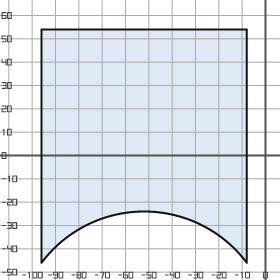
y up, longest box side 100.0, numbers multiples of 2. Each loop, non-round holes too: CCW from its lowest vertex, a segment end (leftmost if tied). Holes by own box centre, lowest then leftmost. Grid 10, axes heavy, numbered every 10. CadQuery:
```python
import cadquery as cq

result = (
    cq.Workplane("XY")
    .moveTo(-96.0, -46.0)
    .threePointArc((-52.0, -24.0), (-8.0, -46.0))
    .lineTo(-8.0, 54.0)
    .lineTo(-96.0, 54.0)
    .close()
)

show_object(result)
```